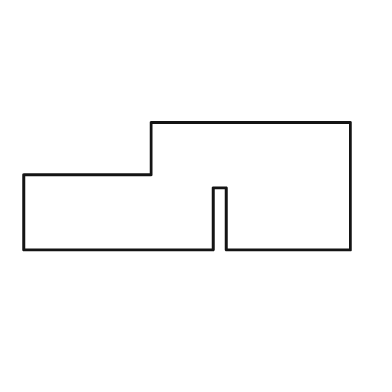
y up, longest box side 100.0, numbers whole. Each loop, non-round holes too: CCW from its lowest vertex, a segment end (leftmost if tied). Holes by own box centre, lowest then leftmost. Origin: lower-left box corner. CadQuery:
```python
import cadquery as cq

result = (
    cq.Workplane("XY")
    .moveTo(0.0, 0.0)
    .lineTo(58.0, 0.0)
    .lineTo(58.0, 19.0)
    .lineTo(62.0, 19.0)
    .lineTo(62.0, 0.0)
    .lineTo(100.0, 0.0)
    .lineTo(100.0, 39.0)
    .lineTo(39.0, 39.0)
    .lineTo(39.0, 23.0)
    .lineTo(0.0, 23.0)
    .close()
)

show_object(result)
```